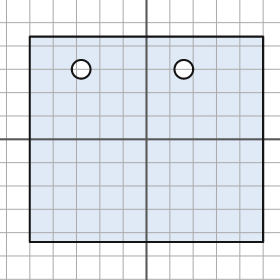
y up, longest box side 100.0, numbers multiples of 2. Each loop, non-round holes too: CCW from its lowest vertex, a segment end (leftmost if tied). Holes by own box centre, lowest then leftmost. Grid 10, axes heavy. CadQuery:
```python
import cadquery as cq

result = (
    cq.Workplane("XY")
    .moveTo(-50.0, -44.0)
    .lineTo(50.0, -44.0)
    .lineTo(50.0, 44.0)
    .lineTo(-50.0, 44.0)
    .close()
    .moveTo(-28.0, 30.0)
    .circle(4.0)
    .moveTo(16.0, 30.0)
    .circle(4.0)
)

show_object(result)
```